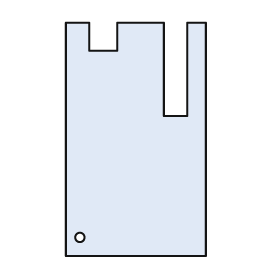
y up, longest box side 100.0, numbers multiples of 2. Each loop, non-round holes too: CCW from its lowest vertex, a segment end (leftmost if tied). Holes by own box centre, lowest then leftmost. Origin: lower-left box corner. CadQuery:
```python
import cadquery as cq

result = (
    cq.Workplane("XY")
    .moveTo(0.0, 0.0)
    .lineTo(60.0, 0.0)
    .lineTo(60.0, 100.0)
    .lineTo(52.0, 100.0)
    .lineTo(52.0, 60.0)
    .lineTo(42.0, 60.0)
    .lineTo(42.0, 100.0)
    .lineTo(22.0, 100.0)
    .lineTo(22.0, 88.0)
    .lineTo(10.0, 88.0)
    .lineTo(10.0, 100.0)
    .lineTo(0.0, 100.0)
    .close()
    .moveTo(6.0, 8.0)
    .circle(2.0)
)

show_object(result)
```